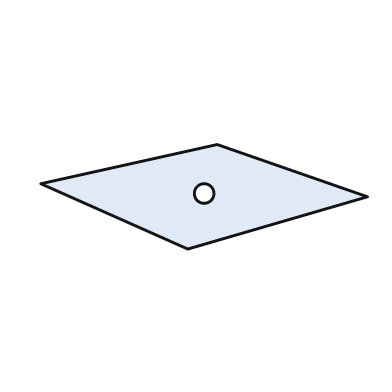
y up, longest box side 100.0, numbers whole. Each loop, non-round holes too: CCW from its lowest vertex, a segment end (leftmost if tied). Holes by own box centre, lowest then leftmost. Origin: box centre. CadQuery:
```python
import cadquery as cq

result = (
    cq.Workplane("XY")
    .moveTo(-5.0, -16.0)
    .lineTo(50.0, 0.0)
    .lineTo(4.0, 16.0)
    .lineTo(-50.0, 4.0)
    .close()
    .moveTo(0.0, 1.0)
    .circle(3.0)
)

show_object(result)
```